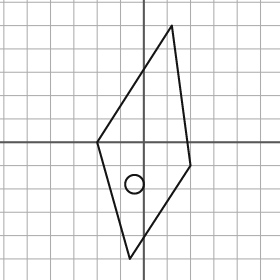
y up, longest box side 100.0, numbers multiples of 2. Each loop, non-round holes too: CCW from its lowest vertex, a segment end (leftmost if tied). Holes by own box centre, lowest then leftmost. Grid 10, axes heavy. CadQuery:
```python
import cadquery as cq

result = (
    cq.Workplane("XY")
    .moveTo(-6.0, -50.0)
    .lineTo(20.0, -10.0)
    .lineTo(12.0, 50.0)
    .lineTo(-20.0, 0.0)
    .close()
    .moveTo(-4.0, -18.0)
    .circle(4.0)
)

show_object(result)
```